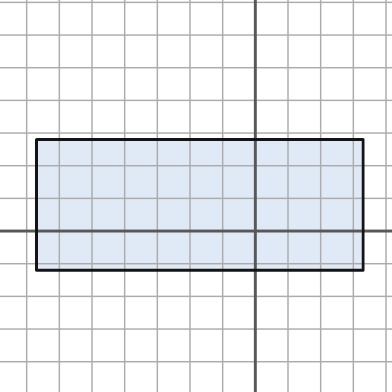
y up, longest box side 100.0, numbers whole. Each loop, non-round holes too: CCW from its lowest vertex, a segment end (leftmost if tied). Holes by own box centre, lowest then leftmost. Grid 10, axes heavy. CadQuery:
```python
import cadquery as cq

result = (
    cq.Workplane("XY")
    .moveTo(-67.0, -12.0)
    .lineTo(33.0, -12.0)
    .lineTo(33.0, 28.0)
    .lineTo(-67.0, 28.0)
    .close()
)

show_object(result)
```